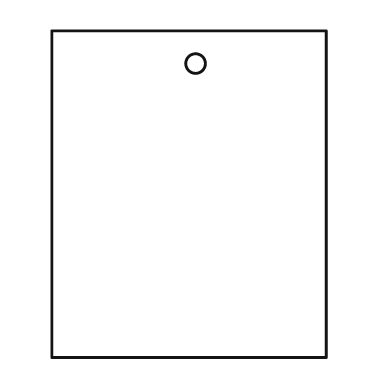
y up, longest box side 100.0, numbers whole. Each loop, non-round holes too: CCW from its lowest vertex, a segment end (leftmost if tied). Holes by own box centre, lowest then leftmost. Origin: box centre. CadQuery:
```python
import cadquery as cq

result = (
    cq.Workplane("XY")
    .moveTo(-42.0, -50.0)
    .lineTo(42.0, -50.0)
    .lineTo(42.0, 50.0)
    .lineTo(-42.0, 50.0)
    .close()
    .moveTo(2.0, 40.0)
    .circle(3.0)
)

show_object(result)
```